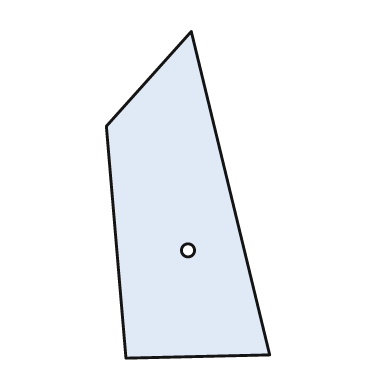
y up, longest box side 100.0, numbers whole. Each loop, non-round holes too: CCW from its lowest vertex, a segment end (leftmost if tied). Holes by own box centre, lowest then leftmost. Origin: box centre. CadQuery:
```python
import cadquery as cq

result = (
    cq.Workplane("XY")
    .moveTo(-19.0, -50.0)
    .lineTo(25.0, -49.0)
    .lineTo(1.0, 50.0)
    .lineTo(-25.0, 21.0)
    .close()
    .moveTo(0.0, -17.0)
    .circle(2.0)
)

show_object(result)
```